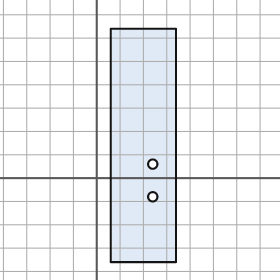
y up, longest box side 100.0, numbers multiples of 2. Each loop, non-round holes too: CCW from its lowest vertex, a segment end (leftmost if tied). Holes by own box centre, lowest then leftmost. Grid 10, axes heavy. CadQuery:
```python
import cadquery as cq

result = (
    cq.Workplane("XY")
    .moveTo(6.0, -36.0)
    .lineTo(34.0, -36.0)
    .lineTo(34.0, 64.0)
    .lineTo(6.0, 64.0)
    .close()
    .moveTo(24.0, -8.0)
    .circle(2.0)
    .moveTo(24.0, 6.0)
    .circle(2.0)
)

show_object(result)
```